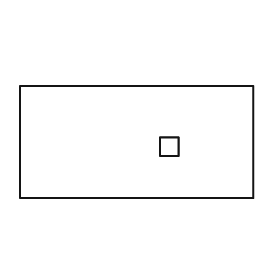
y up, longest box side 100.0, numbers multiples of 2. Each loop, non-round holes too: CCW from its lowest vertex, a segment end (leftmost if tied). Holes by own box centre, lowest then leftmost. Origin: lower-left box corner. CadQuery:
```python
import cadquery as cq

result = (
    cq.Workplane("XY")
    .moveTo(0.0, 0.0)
    .lineTo(100.0, 0.0)
    .lineTo(100.0, 48.0)
    .lineTo(0.0, 48.0)
    .close()
    .moveTo(60.0, 18.0)
    .lineTo(68.0, 18.0)
    .lineTo(68.0, 26.0)
    .lineTo(60.0, 26.0)
    .close()
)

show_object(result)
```